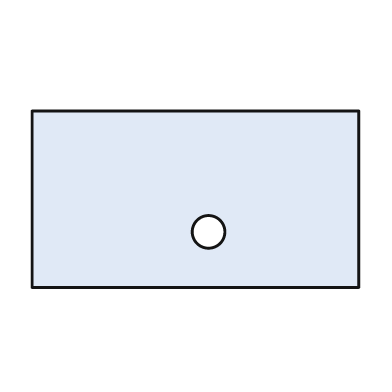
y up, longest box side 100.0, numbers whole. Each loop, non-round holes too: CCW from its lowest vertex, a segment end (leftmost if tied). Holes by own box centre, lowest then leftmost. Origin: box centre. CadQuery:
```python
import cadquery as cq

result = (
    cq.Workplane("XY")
    .moveTo(-50.0, -27.0)
    .lineTo(50.0, -27.0)
    .lineTo(50.0, 27.0)
    .lineTo(-50.0, 27.0)
    .close()
    .moveTo(4.0, -10.0)
    .circle(5.0)
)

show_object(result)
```